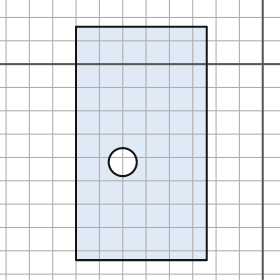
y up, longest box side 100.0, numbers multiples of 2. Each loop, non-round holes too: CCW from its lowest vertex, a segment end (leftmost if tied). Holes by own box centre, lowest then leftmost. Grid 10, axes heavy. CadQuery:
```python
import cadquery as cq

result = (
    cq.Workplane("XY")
    .moveTo(-80.0, -84.0)
    .lineTo(-24.0, -84.0)
    .lineTo(-24.0, 16.0)
    .lineTo(-80.0, 16.0)
    .close()
    .moveTo(-60.0, -42.0)
    .circle(6.0)
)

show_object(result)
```